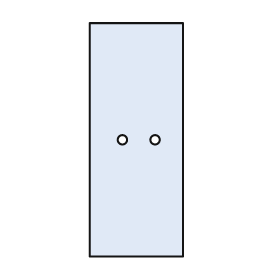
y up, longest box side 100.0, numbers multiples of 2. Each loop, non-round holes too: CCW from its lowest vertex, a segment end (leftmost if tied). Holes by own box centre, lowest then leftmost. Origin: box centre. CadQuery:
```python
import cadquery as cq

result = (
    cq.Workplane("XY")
    .moveTo(-20.0, -50.0)
    .lineTo(20.0, -50.0)
    .lineTo(20.0, 50.0)
    .lineTo(-20.0, 50.0)
    .close()
    .moveTo(-6.0, 0.0)
    .circle(2.0)
    .moveTo(8.0, 0.0)
    .circle(2.0)
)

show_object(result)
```